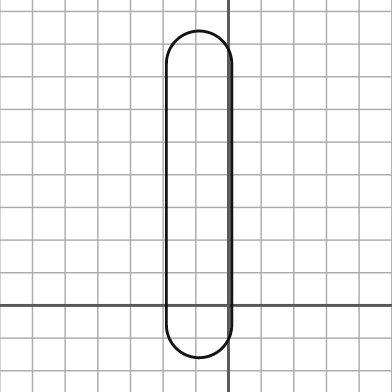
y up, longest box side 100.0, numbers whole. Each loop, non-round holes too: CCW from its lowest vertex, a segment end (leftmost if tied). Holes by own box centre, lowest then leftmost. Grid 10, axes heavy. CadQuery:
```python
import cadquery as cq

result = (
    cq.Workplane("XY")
    .moveTo(-19.0, -6.0)
    .threePointArc((-9.0, -16.0), (1.0, -6.0))
    .lineTo(1.0, 74.0)
    .threePointArc((-9.0, 84.0), (-19.0, 74.0))
    .close()
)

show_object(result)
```